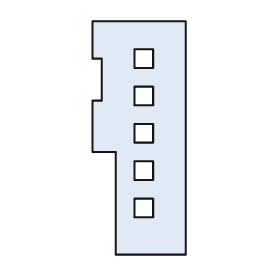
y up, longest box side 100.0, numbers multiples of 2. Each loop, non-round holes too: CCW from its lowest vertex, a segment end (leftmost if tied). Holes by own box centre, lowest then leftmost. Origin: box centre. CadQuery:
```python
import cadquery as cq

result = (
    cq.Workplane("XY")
    .moveTo(-10.0, -50.0)
    .lineTo(20.0, -50.0)
    .lineTo(20.0, 50.0)
    .lineTo(-20.0, 50.0)
    .lineTo(-20.0, 34.0)
    .lineTo(-16.0, 34.0)
    .lineTo(-16.0, 16.0)
    .lineTo(-20.0, 16.0)
    .lineTo(-20.0, -6.0)
    .lineTo(-10.0, -6.0)
    .close()
    .moveTo(-2.0, -34.0)
    .lineTo(6.0, -34.0)
    .lineTo(6.0, -26.0)
    .lineTo(-2.0, -26.0)
    .close()
    .moveTo(-2.0, -18.0)
    .lineTo(6.0, -18.0)
    .lineTo(6.0, -10.0)
    .lineTo(-2.0, -10.0)
    .close()
    .moveTo(-2.0, -2.0)
    .lineTo(6.0, -2.0)
    .lineTo(6.0, 6.0)
    .lineTo(-2.0, 6.0)
    .close()
    .moveTo(-2.0, 14.0)
    .lineTo(6.0, 14.0)
    .lineTo(6.0, 22.0)
    .lineTo(-2.0, 22.0)
    .close()
    .moveTo(-2.0, 30.0)
    .lineTo(6.0, 30.0)
    .lineTo(6.0, 38.0)
    .lineTo(-2.0, 38.0)
    .close()
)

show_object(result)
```